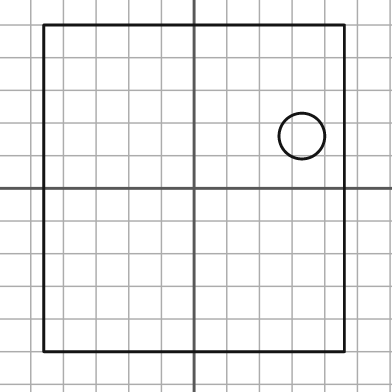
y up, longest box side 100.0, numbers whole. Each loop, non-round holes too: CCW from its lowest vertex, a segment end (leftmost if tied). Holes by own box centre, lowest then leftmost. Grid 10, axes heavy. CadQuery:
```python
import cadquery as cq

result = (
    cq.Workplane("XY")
    .moveTo(-46.0, -50.0)
    .lineTo(46.0, -50.0)
    .lineTo(46.0, 50.0)
    .lineTo(-46.0, 50.0)
    .close()
    .moveTo(33.0, 16.0)
    .circle(7.0)
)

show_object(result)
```